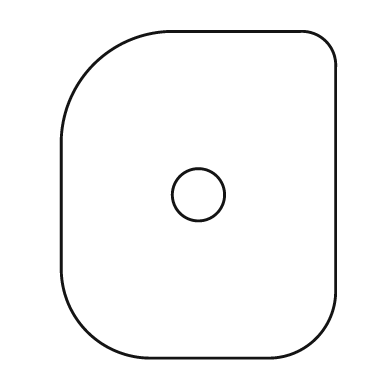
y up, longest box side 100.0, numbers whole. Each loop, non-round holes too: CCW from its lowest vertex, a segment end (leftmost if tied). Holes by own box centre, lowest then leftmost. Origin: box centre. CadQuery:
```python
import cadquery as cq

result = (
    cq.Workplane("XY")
    .moveTo(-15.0, -50.0)
    .lineTo(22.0, -50.0)
    .threePointArc((36.0, -44.0), (42.0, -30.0))
    .lineTo(42.0, 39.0)
    .threePointArc((39.0, 47.0), (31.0, 50.0))
    .lineTo(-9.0, 50.0)
    .threePointArc((-32.0, 40.0), (-42.0, 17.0))
    .lineTo(-42.0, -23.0)
    .threePointArc((-34.0, -42.0), (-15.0, -50.0))
    .close()
    .moveTo(0.0, 0.0)
    .circle(8.0)
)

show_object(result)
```